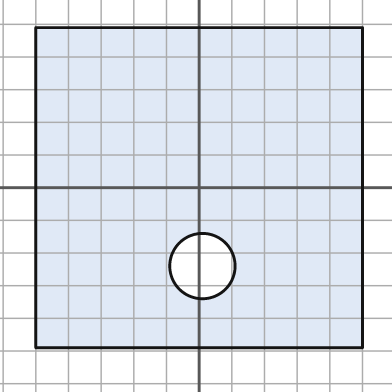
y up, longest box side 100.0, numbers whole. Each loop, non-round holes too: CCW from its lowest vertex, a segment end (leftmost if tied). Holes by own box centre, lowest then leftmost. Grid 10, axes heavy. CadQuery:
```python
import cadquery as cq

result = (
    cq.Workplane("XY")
    .moveTo(-50.0, -49.0)
    .lineTo(50.0, -49.0)
    .lineTo(50.0, 49.0)
    .lineTo(-50.0, 49.0)
    .close()
    .moveTo(1.0, -24.0)
    .circle(10.0)
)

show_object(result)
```